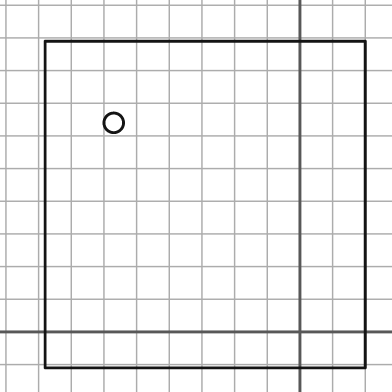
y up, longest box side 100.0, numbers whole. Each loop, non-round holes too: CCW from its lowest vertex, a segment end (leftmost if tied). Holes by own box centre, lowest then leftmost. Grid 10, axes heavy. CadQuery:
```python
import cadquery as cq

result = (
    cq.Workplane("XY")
    .moveTo(-78.0, -11.0)
    .lineTo(20.0, -11.0)
    .lineTo(20.0, 89.0)
    .lineTo(-78.0, 89.0)
    .close()
    .moveTo(-57.0, 64.0)
    .circle(3.0)
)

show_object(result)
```